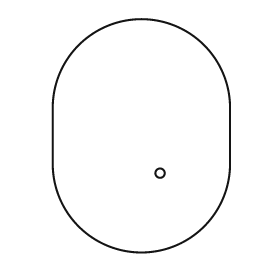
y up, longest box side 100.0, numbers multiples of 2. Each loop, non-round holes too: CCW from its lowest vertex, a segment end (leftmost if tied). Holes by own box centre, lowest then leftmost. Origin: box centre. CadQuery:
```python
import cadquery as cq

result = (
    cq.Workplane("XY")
    .moveTo(-38.0, -12.0)
    .threePointArc((0.0, -50.0), (38.0, -12.0))
    .lineTo(38.0, 12.0)
    .threePointArc((0.0, 50.0), (-38.0, 12.0))
    .close()
    .moveTo(8.0, -16.0)
    .circle(2.0)
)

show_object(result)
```